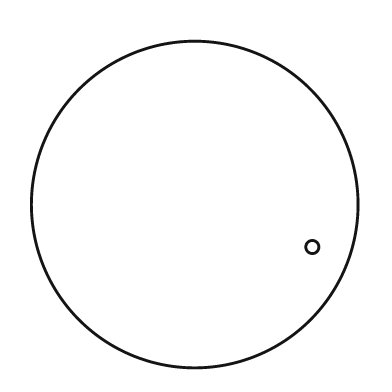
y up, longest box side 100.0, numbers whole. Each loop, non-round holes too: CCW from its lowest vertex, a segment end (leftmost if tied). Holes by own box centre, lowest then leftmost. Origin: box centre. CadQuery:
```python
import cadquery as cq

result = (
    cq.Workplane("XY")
    .moveTo(0.0, 0.0)
    .circle(50.0)
    .moveTo(36.0, -13.0)
    .circle(2.0)
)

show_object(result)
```